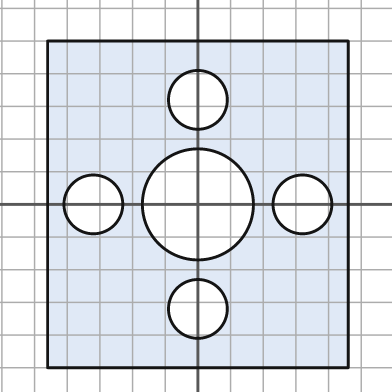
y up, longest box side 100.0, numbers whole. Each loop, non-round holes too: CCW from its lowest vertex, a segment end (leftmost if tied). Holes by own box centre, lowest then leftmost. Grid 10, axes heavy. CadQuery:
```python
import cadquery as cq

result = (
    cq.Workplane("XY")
    .moveTo(-46.0, -50.0)
    .lineTo(46.0, -50.0)
    .lineTo(46.0, 50.0)
    .lineTo(-46.0, 50.0)
    .close()
    .moveTo(0.0, -32.0)
    .circle(9.0)
    .moveTo(-32.0, 0.0)
    .circle(9.0)
    .moveTo(0.0, 0.0)
    .circle(17.0)
    .moveTo(32.0, 0.0)
    .circle(9.0)
    .moveTo(0.0, 32.0)
    .circle(9.0)
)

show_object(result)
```